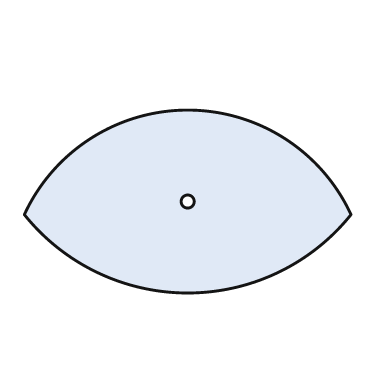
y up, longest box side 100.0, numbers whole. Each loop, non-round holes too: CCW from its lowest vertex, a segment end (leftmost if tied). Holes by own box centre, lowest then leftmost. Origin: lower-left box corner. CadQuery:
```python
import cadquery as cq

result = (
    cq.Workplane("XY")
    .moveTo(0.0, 24.0)
    .threePointArc((50.0, 0.0), (100.0, 24.0))
    .threePointArc((50.0, 56.0), (0.0, 24.0))
    .close()
    .moveTo(50.0, 28.0)
    .circle(2.0)
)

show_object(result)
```